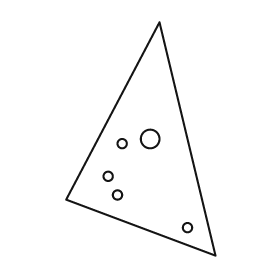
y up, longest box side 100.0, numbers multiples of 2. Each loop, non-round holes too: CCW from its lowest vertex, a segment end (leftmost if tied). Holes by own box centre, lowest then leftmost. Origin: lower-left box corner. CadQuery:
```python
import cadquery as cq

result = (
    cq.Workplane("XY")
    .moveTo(64.0, 0.0)
    .lineTo(40.0, 100.0)
    .lineTo(0.0, 24.0)
    .close()
    .moveTo(52.0, 12.0)
    .circle(2.0)
    .moveTo(22.0, 26.0)
    .circle(2.0)
    .moveTo(18.0, 34.0)
    .circle(2.0)
    .moveTo(24.0, 48.0)
    .circle(2.0)
    .moveTo(36.0, 50.0)
    .circle(4.0)
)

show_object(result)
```